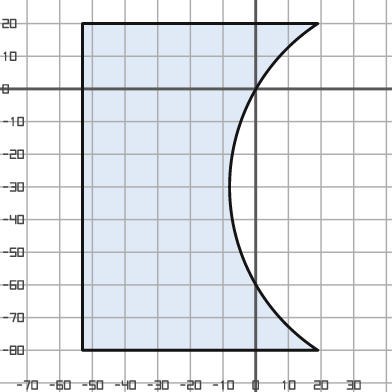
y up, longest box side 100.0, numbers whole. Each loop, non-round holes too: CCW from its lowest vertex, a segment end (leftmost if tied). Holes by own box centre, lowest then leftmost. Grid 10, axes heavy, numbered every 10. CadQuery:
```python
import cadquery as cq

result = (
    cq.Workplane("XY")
    .moveTo(-53.0, -80.0)
    .lineTo(19.0, -80.0)
    .threePointArc((-8.0, -30.0), (19.0, 20.0))
    .lineTo(-53.0, 20.0)
    .close()
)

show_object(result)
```